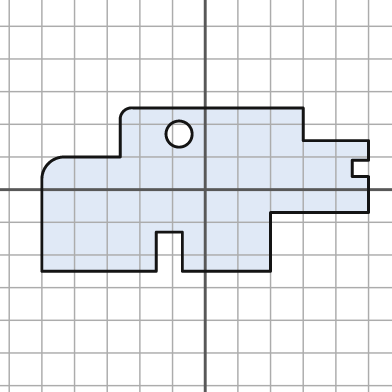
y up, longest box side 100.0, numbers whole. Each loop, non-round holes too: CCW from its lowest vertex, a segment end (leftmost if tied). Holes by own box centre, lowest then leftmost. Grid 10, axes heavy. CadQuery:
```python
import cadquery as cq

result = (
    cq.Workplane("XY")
    .moveTo(-50.0, -25.0)
    .lineTo(-15.0, -25.0)
    .lineTo(-15.0, -13.0)
    .lineTo(-7.0, -13.0)
    .lineTo(-7.0, -25.0)
    .lineTo(20.0, -25.0)
    .lineTo(20.0, -7.0)
    .lineTo(50.0, -7.0)
    .lineTo(50.0, 4.0)
    .lineTo(45.0, 4.0)
    .lineTo(45.0, 9.0)
    .lineTo(50.0, 9.0)
    .lineTo(50.0, 15.0)
    .lineTo(30.0, 15.0)
    .lineTo(30.0, 25.0)
    .lineTo(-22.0, 25.0)
    .threePointArc((-25.0, 24.0), (-26.0, 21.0))
    .lineTo(-26.0, 10.0)
    .lineTo(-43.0, 10.0)
    .threePointArc((-48.0, 8.0), (-50.0, 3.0))
    .close()
    .moveTo(-8.0, 17.0)
    .circle(4.0)
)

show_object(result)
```